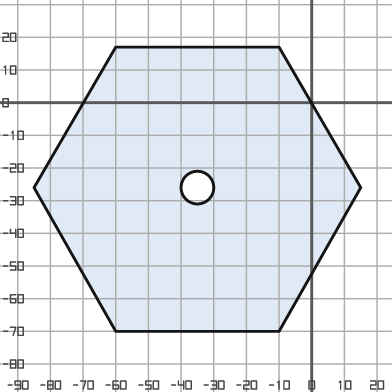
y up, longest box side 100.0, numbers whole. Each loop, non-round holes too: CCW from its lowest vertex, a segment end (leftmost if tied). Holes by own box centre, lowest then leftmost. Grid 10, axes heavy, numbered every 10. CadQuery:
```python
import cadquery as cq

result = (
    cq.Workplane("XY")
    .moveTo(-60.0, -70.0)
    .lineTo(-10.0, -70.0)
    .lineTo(15.0, -26.0)
    .lineTo(-10.0, 17.0)
    .lineTo(-60.0, 17.0)
    .lineTo(-85.0, -26.0)
    .close()
    .moveTo(-35.0, -26.0)
    .circle(5.0)
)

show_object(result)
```